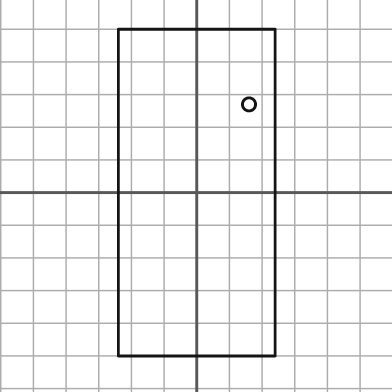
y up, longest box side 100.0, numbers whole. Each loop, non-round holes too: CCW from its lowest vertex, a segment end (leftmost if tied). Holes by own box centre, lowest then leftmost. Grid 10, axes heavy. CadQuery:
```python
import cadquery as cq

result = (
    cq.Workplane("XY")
    .moveTo(-24.0, -50.0)
    .lineTo(24.0, -50.0)
    .lineTo(24.0, 50.0)
    .lineTo(-24.0, 50.0)
    .close()
    .moveTo(16.0, 27.0)
    .circle(2.0)
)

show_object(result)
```